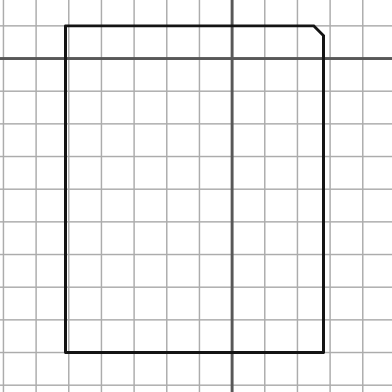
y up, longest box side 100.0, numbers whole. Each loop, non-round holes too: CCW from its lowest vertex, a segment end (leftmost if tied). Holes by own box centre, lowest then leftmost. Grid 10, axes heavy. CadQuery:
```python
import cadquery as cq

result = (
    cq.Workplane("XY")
    .moveTo(-51.0, -90.0)
    .lineTo(28.0, -90.0)
    .lineTo(28.0, 7.0)
    .lineTo(25.0, 10.0)
    .lineTo(-51.0, 10.0)
    .close()
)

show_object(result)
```